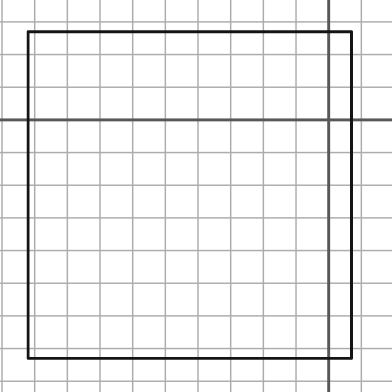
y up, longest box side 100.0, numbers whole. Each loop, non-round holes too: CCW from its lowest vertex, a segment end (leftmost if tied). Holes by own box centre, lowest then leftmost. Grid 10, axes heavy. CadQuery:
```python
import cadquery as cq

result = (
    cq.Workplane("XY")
    .moveTo(-92.0, -73.0)
    .lineTo(7.0, -73.0)
    .lineTo(7.0, 27.0)
    .lineTo(-92.0, 27.0)
    .close()
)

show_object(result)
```